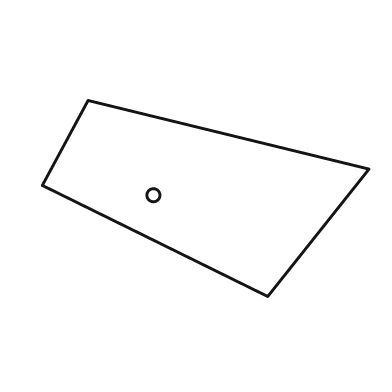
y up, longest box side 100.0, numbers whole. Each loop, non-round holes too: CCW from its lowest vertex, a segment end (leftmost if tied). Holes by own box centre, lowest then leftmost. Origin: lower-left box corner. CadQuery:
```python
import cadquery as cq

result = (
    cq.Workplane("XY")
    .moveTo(69.0, 0.0)
    .lineTo(100.0, 39.0)
    .lineTo(14.0, 60.0)
    .lineTo(0.0, 34.0)
    .close()
    .moveTo(34.0, 31.0)
    .circle(2.0)
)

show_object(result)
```